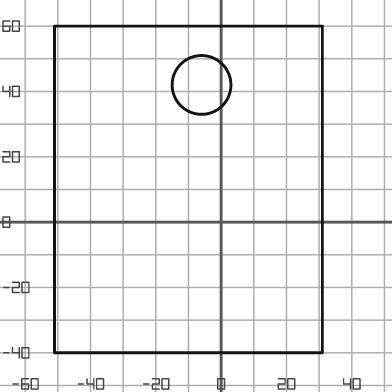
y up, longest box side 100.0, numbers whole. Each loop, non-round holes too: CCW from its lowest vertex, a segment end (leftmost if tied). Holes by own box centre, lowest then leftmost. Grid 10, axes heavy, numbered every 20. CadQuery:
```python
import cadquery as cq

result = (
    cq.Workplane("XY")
    .moveTo(-51.0, -40.0)
    .lineTo(31.0, -40.0)
    .lineTo(31.0, 60.0)
    .lineTo(-51.0, 60.0)
    .close()
    .moveTo(-6.0, 42.0)
    .circle(9.0)
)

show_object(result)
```